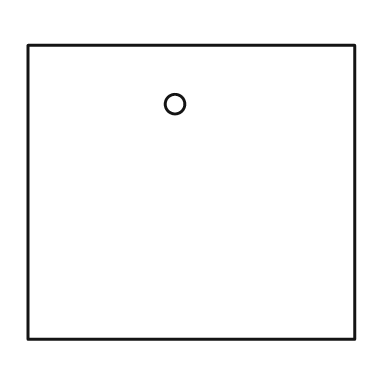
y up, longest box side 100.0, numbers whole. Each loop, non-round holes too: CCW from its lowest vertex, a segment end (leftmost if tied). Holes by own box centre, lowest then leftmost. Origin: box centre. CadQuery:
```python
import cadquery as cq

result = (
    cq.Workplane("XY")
    .moveTo(-50.0, -45.0)
    .lineTo(50.0, -45.0)
    .lineTo(50.0, 45.0)
    .lineTo(-50.0, 45.0)
    .close()
    .moveTo(-5.0, 27.0)
    .circle(3.0)
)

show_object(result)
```